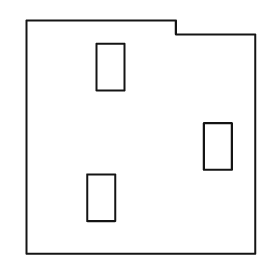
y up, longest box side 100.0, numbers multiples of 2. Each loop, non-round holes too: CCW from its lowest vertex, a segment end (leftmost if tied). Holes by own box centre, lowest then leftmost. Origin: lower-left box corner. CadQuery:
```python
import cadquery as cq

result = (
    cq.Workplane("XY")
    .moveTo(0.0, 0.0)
    .lineTo(98.0, 0.0)
    .lineTo(98.0, 94.0)
    .lineTo(64.0, 94.0)
    .lineTo(64.0, 100.0)
    .lineTo(0.0, 100.0)
    .close()
    .moveTo(26.0, 14.0)
    .lineTo(38.0, 14.0)
    .lineTo(38.0, 34.0)
    .lineTo(26.0, 34.0)
    .close()
    .moveTo(76.0, 36.0)
    .lineTo(88.0, 36.0)
    .lineTo(88.0, 56.0)
    .lineTo(76.0, 56.0)
    .close()
    .moveTo(30.0, 70.0)
    .lineTo(42.0, 70.0)
    .lineTo(42.0, 90.0)
    .lineTo(30.0, 90.0)
    .close()
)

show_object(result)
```